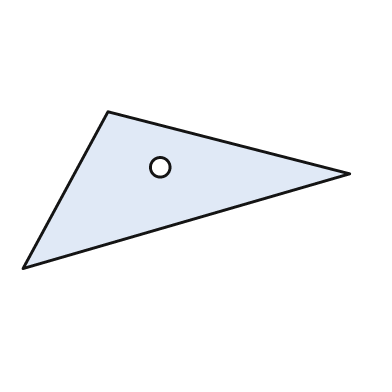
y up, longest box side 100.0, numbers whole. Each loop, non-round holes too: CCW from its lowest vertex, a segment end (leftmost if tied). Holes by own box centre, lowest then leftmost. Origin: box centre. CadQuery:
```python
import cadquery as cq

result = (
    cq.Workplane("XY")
    .moveTo(-50.0, -24.0)
    .lineTo(50.0, 5.0)
    .lineTo(-24.0, 24.0)
    .close()
    .moveTo(-8.0, 7.0)
    .circle(3.0)
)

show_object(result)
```